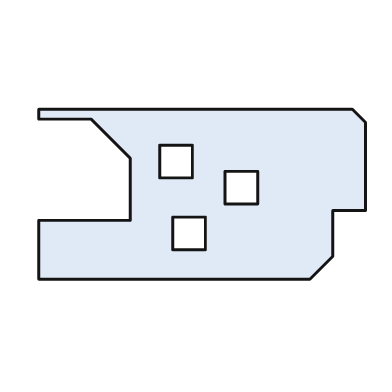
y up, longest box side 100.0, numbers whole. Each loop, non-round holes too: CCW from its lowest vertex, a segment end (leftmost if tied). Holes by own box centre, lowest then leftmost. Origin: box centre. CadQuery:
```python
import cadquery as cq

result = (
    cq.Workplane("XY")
    .moveTo(-50.0, -26.0)
    .lineTo(33.0, -26.0)
    .lineTo(40.0, -19.0)
    .lineTo(40.0, -5.0)
    .lineTo(50.0, -5.0)
    .lineTo(50.0, 22.0)
    .lineTo(46.0, 26.0)
    .lineTo(-50.0, 26.0)
    .lineTo(-50.0, 23.0)
    .lineTo(-34.0, 23.0)
    .lineTo(-22.0, 11.0)
    .lineTo(-22.0, -8.0)
    .lineTo(-50.0, -8.0)
    .close()
    .moveTo(-9.0, -17.0)
    .lineTo(1.0, -17.0)
    .lineTo(1.0, -7.0)
    .lineTo(-9.0, -7.0)
    .close()
    .moveTo(7.0, -3.0)
    .lineTo(17.0, -3.0)
    .lineTo(17.0, 7.0)
    .lineTo(7.0, 7.0)
    .close()
    .moveTo(-13.0, 5.0)
    .lineTo(-3.0, 5.0)
    .lineTo(-3.0, 15.0)
    .lineTo(-13.0, 15.0)
    .close()
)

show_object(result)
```